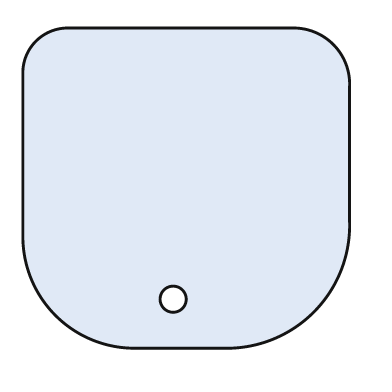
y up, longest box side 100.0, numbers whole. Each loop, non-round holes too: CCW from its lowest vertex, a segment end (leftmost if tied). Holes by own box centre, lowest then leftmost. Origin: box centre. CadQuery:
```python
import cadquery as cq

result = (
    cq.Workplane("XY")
    .moveTo(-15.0, -49.0)
    .lineTo(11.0, -49.0)
    .threePointArc((39.0, -38.0), (50.0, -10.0))
    .lineTo(50.0, 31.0)
    .threePointArc((45.0, 44.0), (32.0, 49.0))
    .lineTo(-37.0, 49.0)
    .threePointArc((-46.0, 45.0), (-50.0, 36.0))
    .lineTo(-50.0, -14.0)
    .threePointArc((-40.0, -39.0), (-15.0, -49.0))
    .close()
    .moveTo(-4.0, -34.0)
    .circle(4.0)
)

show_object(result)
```